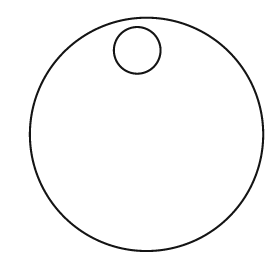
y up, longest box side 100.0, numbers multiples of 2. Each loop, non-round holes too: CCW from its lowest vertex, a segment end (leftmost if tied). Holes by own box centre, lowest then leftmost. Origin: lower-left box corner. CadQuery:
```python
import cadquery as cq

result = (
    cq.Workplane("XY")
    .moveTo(50.0, 50.0)
    .circle(50.0)
    .moveTo(46.0, 86.0)
    .circle(10.0)
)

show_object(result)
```